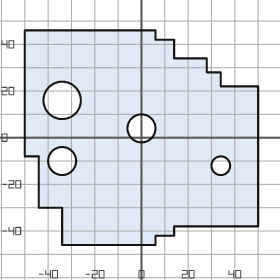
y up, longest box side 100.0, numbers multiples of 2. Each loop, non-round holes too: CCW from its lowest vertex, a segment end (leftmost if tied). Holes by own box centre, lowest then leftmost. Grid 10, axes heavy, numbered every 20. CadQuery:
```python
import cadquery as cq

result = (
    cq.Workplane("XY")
    .moveTo(-34.0, -46.0)
    .lineTo(6.0, -46.0)
    .lineTo(6.0, -42.0)
    .lineTo(14.0, -42.0)
    .lineTo(14.0, -38.0)
    .lineTo(50.0, -38.0)
    .lineTo(50.0, 22.0)
    .lineTo(34.0, 22.0)
    .lineTo(34.0, 28.0)
    .lineTo(28.0, 28.0)
    .lineTo(28.0, 34.0)
    .lineTo(14.0, 34.0)
    .lineTo(14.0, 42.0)
    .lineTo(6.0, 42.0)
    .lineTo(6.0, 46.0)
    .lineTo(-50.0, 46.0)
    .lineTo(-50.0, -8.0)
    .lineTo(-44.0, -8.0)
    .lineTo(-44.0, -30.0)
    .lineTo(-34.0, -30.0)
    .close()
    .moveTo(34.0, -12.0)
    .circle(4.0)
    .moveTo(-34.0, -10.0)
    .circle(6.0)
    .moveTo(0.0, 4.0)
    .circle(6.0)
    .moveTo(-34.0, 16.0)
    .circle(8.0)
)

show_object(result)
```